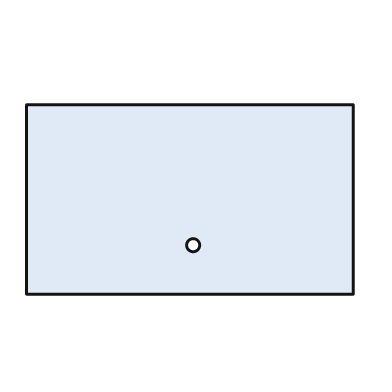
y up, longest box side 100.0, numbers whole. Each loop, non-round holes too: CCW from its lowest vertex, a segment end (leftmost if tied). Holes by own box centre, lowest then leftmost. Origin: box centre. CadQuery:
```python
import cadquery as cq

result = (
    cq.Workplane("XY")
    .moveTo(-50.0, -29.0)
    .lineTo(50.0, -29.0)
    .lineTo(50.0, 29.0)
    .lineTo(-50.0, 29.0)
    .close()
    .moveTo(1.0, -14.0)
    .circle(2.0)
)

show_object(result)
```